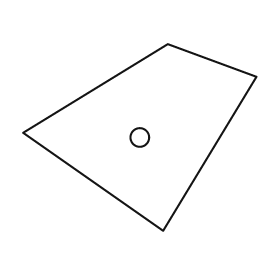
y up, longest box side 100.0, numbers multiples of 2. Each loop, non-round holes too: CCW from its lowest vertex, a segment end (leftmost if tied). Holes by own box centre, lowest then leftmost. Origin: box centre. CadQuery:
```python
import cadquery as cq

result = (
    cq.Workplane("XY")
    .moveTo(10.0, -40.0)
    .lineTo(50.0, 26.0)
    .lineTo(12.0, 40.0)
    .lineTo(-50.0, 2.0)
    .close()
    .moveTo(0.0, 0.0)
    .circle(4.0)
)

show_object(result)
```